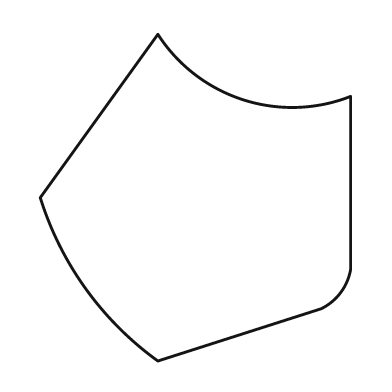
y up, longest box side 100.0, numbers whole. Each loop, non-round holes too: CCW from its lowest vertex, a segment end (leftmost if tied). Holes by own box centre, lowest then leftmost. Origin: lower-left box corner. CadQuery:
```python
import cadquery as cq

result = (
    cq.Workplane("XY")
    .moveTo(36.0, 0.0)
    .lineTo(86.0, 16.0)
    .threePointArc((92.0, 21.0), (95.0, 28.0))
    .lineTo(95.0, 81.0)
    .threePointArc((62.0, 80.0), (36.0, 100.0))
    .lineTo(0.0, 50.0)
    .threePointArc((14.0, 22.0), (36.0, 0.0))
    .close()
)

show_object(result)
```